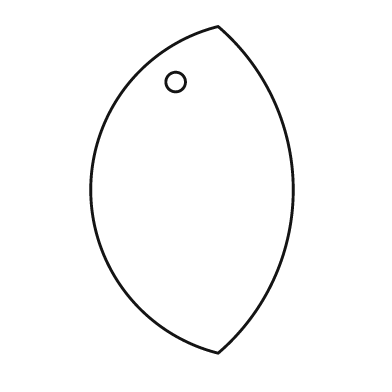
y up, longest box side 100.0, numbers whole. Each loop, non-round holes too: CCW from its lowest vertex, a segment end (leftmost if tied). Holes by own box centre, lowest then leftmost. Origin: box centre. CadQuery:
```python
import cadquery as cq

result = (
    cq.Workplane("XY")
    .moveTo(8.0, -50.0)
    .threePointArc((31.0, 0.0), (8.0, 50.0))
    .threePointArc((-31.0, 0.0), (8.0, -50.0))
    .close()
    .moveTo(-5.0, 33.0)
    .circle(3.0)
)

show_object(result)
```